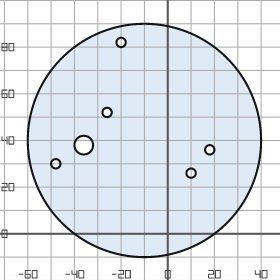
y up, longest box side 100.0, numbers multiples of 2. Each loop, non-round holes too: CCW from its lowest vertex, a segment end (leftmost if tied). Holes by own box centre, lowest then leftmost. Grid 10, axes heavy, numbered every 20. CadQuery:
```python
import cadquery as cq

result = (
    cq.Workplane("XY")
    .moveTo(-10.0, 40.0)
    .circle(50.0)
    .moveTo(10.0, 26.0)
    .circle(2.0)
    .moveTo(-48.0, 30.0)
    .circle(2.0)
    .moveTo(18.0, 36.0)
    .circle(2.0)
    .moveTo(-36.0, 38.0)
    .circle(4.0)
    .moveTo(-26.0, 52.0)
    .circle(2.0)
    .moveTo(-20.0, 82.0)
    .circle(2.0)
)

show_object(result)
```